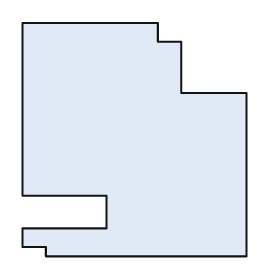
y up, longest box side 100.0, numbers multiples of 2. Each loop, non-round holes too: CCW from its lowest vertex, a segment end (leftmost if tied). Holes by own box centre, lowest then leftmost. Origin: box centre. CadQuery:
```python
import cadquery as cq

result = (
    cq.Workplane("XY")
    .moveTo(-38.0, -50.0)
    .lineTo(48.0, -50.0)
    .lineTo(48.0, 20.0)
    .lineTo(20.0, 20.0)
    .lineTo(20.0, 42.0)
    .lineTo(10.0, 42.0)
    .lineTo(10.0, 50.0)
    .lineTo(-48.0, 50.0)
    .lineTo(-48.0, -24.0)
    .lineTo(-12.0, -24.0)
    .lineTo(-12.0, -38.0)
    .lineTo(-48.0, -38.0)
    .lineTo(-48.0, -46.0)
    .lineTo(-38.0, -46.0)
    .close()
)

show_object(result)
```